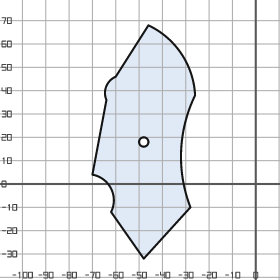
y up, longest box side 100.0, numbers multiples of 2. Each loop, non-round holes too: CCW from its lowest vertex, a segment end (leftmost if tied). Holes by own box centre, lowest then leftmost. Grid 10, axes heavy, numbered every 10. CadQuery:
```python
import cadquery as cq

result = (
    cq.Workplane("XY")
    .moveTo(-48.0, -32.0)
    .lineTo(-28.0, -10.0)
    .threePointArc((-32.0, 14.0), (-26.0, 38.0))
    .threePointArc((-32.0, 56.0), (-46.0, 68.0))
    .lineTo(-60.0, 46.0)
    .threePointArc((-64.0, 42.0), (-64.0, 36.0))
    .lineTo(-70.0, 4.0)
    .threePointArc((-62.0, -2.0), (-62.0, -12.0))
    .close()
    .moveTo(-48.0, 18.0)
    .circle(2.0)
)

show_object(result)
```